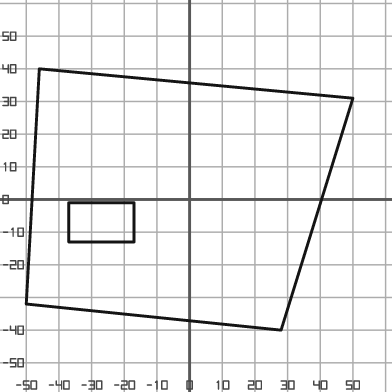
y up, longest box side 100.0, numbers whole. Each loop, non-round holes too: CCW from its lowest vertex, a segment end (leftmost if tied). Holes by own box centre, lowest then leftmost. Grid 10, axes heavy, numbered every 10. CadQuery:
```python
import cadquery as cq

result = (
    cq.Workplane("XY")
    .moveTo(28.0, -40.0)
    .lineTo(50.0, 31.0)
    .lineTo(-46.0, 40.0)
    .lineTo(-50.0, -32.0)
    .close()
    .moveTo(-37.0, -13.0)
    .lineTo(-17.0, -13.0)
    .lineTo(-17.0, -1.0)
    .lineTo(-37.0, -1.0)
    .close()
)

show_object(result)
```